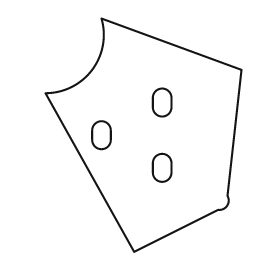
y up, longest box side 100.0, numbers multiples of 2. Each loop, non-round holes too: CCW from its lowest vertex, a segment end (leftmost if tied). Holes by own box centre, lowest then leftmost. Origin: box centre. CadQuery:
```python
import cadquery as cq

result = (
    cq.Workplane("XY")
    .moveTo(-4.0, -50.0)
    .lineTo(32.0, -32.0)
    .threePointArc((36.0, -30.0), (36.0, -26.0))
    .lineTo(42.0, 28.0)
    .lineTo(-18.0, 50.0)
    .threePointArc((-22.0, 28.0), (-42.0, 18.0))
    .close()
    .moveTo(4.0, -16.0)
    .threePointArc((8.0, -20.0), (12.0, -16.0))
    .lineTo(12.0, -12.0)
    .threePointArc((8.0, -8.0), (4.0, -12.0))
    .close()
    .moveTo(-22.0, -2.0)
    .threePointArc((-18.0, -6.0), (-14.0, -2.0))
    .lineTo(-14.0, 2.0)
    .threePointArc((-18.0, 6.0), (-22.0, 2.0))
    .close()
    .moveTo(4.0, 12.0)
    .threePointArc((8.0, 8.0), (12.0, 12.0))
    .lineTo(12.0, 16.0)
    .threePointArc((8.0, 20.0), (4.0, 16.0))
    .close()
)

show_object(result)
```